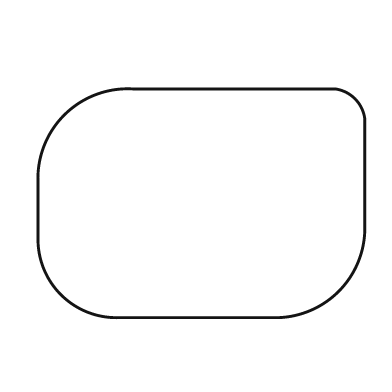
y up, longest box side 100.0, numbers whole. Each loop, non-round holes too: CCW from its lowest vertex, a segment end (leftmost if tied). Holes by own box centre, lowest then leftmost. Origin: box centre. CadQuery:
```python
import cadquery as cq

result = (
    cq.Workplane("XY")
    .moveTo(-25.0, -35.0)
    .lineTo(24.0, -35.0)
    .threePointArc((42.0, -27.0), (50.0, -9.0))
    .lineTo(50.0, 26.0)
    .threePointArc((47.0, 32.0), (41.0, 35.0))
    .lineTo(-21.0, 35.0)
    .threePointArc((-42.0, 27.0), (-50.0, 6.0))
    .lineTo(-50.0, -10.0)
    .threePointArc((-43.0, -28.0), (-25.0, -35.0))
    .close()
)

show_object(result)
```